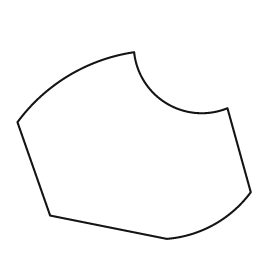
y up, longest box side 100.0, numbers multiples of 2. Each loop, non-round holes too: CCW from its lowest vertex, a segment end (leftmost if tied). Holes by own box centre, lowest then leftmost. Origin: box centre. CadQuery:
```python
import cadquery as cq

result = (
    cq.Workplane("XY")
    .moveTo(14.0, -40.0)
    .threePointArc((34.0, -34.0), (50.0, -20.0))
    .lineTo(40.0, 16.0)
    .threePointArc((14.0, 18.0), (0.0, 40.0))
    .threePointArc((-28.0, 30.0), (-50.0, 10.0))
    .lineTo(-36.0, -30.0)
    .close()
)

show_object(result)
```